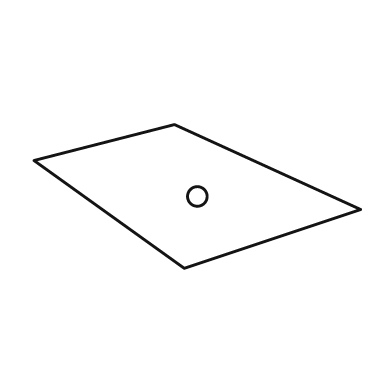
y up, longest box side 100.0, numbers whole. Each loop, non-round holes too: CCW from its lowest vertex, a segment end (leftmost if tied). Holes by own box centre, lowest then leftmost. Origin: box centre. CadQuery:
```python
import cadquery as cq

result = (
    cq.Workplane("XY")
    .moveTo(-4.0, -22.0)
    .lineTo(50.0, -4.0)
    .lineTo(-7.0, 22.0)
    .lineTo(-50.0, 11.0)
    .close()
    .moveTo(0.0, 0.0)
    .circle(3.0)
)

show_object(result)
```